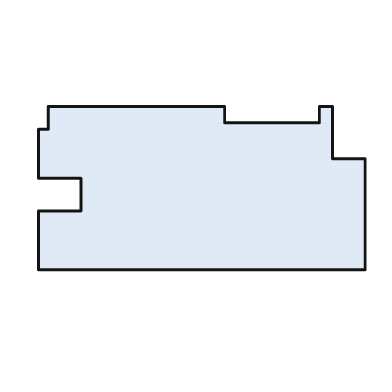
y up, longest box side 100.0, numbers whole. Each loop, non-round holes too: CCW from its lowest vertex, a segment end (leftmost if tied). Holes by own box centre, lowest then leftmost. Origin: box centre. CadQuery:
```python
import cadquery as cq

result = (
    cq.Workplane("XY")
    .moveTo(-50.0, -25.0)
    .lineTo(50.0, -25.0)
    .lineTo(50.0, 9.0)
    .lineTo(40.0, 9.0)
    .lineTo(40.0, 25.0)
    .lineTo(36.0, 25.0)
    .lineTo(36.0, 20.0)
    .lineTo(7.0, 20.0)
    .lineTo(7.0, 25.0)
    .lineTo(-47.0, 25.0)
    .lineTo(-47.0, 18.0)
    .lineTo(-50.0, 18.0)
    .lineTo(-50.0, 3.0)
    .lineTo(-37.0, 3.0)
    .lineTo(-37.0, -7.0)
    .lineTo(-50.0, -7.0)
    .close()
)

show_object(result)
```